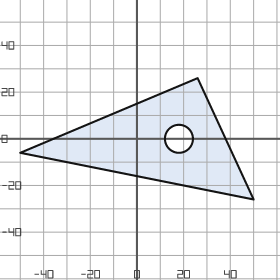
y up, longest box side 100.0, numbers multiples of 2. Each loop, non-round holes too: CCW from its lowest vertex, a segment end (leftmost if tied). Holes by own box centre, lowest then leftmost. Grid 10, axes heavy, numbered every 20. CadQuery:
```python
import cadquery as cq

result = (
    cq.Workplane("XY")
    .moveTo(50.0, -26.0)
    .lineTo(26.0, 26.0)
    .lineTo(-50.0, -6.0)
    .close()
    .moveTo(18.0, 0.0)
    .circle(6.0)
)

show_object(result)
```